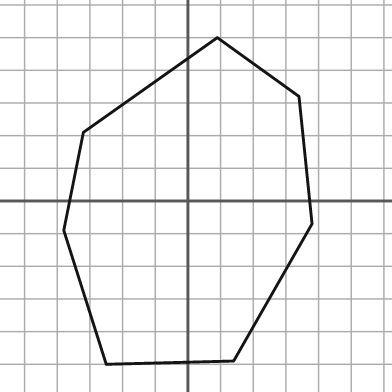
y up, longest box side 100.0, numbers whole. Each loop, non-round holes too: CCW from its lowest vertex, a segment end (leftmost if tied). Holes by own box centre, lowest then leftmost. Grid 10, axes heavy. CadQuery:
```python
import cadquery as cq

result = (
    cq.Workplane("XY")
    .moveTo(-25.0, -50.0)
    .lineTo(14.0, -49.0)
    .lineTo(38.0, -7.0)
    .lineTo(34.0, 32.0)
    .lineTo(9.0, 50.0)
    .lineTo(-32.0, 21.0)
    .lineTo(-38.0, -9.0)
    .close()
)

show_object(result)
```